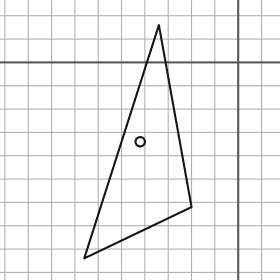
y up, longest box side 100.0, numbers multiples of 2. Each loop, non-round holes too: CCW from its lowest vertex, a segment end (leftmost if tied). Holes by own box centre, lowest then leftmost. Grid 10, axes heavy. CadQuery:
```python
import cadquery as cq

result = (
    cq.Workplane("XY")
    .moveTo(-66.0, -84.0)
    .lineTo(-20.0, -62.0)
    .lineTo(-34.0, 16.0)
    .close()
    .moveTo(-42.0, -34.0)
    .circle(2.0)
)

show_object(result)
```